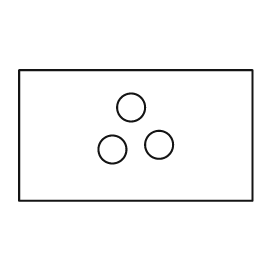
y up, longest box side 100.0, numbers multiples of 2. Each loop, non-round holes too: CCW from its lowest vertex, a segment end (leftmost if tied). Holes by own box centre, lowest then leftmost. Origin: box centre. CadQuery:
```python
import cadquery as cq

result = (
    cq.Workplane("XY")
    .moveTo(-50.0, -28.0)
    .lineTo(50.0, -28.0)
    .lineTo(50.0, 28.0)
    .lineTo(-50.0, 28.0)
    .close()
    .moveTo(-10.0, -6.0)
    .circle(6.0)
    .moveTo(10.0, -4.0)
    .circle(6.0)
    .moveTo(-2.0, 12.0)
    .circle(6.0)
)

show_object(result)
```